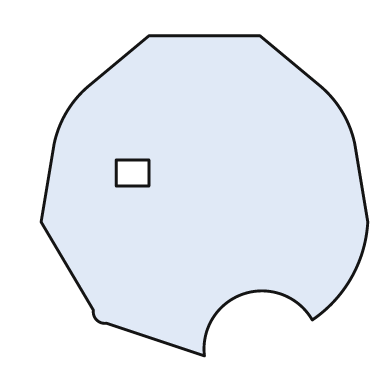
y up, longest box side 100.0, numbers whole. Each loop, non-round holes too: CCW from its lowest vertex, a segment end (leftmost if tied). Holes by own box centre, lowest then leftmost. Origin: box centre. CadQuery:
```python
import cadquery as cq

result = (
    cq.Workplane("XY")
    .moveTo(0.0, -49.0)
    .threePointArc((12.0, -30.0), (33.0, -38.0))
    .threePointArc((45.0, -25.0), (50.0, -8.0))
    .lineTo(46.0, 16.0)
    .threePointArc((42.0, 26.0), (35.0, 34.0))
    .lineTo(17.0, 49.0)
    .lineTo(-17.0, 49.0)
    .lineTo(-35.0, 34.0)
    .threePointArc((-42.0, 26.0), (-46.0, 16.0))
    .lineTo(-50.0, -8.0)
    .lineTo(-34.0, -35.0)
    .threePointArc((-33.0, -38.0), (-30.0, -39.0))
    .close()
    .moveTo(-27.0, 3.0)
    .lineTo(-17.0, 3.0)
    .lineTo(-17.0, 11.0)
    .lineTo(-27.0, 11.0)
    .close()
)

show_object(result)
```